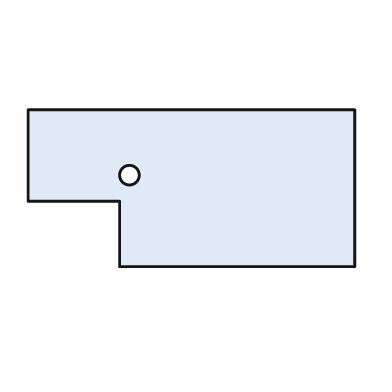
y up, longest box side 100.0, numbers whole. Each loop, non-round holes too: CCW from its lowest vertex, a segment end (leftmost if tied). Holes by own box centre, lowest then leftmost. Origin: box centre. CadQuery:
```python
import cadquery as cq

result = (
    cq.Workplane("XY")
    .moveTo(-22.0, -24.0)
    .lineTo(50.0, -24.0)
    .lineTo(50.0, 24.0)
    .lineTo(-50.0, 24.0)
    .lineTo(-50.0, -4.0)
    .lineTo(-22.0, -4.0)
    .close()
    .moveTo(-19.0, 4.0)
    .circle(3.0)
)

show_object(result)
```